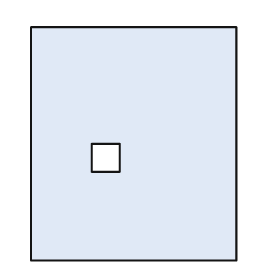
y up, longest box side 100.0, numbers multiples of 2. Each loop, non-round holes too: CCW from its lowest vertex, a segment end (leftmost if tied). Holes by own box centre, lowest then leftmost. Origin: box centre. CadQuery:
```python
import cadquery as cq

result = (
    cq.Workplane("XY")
    .moveTo(-44.0, -50.0)
    .lineTo(44.0, -50.0)
    .lineTo(44.0, 50.0)
    .lineTo(-44.0, 50.0)
    .close()
    .moveTo(-18.0, -12.0)
    .lineTo(-6.0, -12.0)
    .lineTo(-6.0, 0.0)
    .lineTo(-18.0, 0.0)
    .close()
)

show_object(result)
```